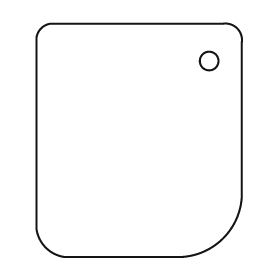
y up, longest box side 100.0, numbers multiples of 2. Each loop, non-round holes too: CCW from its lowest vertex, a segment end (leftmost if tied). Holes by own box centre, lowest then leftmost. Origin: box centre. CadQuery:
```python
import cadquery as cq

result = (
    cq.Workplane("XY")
    .moveTo(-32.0, -50.0)
    .lineTo(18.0, -50.0)
    .threePointArc((36.0, -42.0), (44.0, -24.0))
    .lineTo(44.0, 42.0)
    .threePointArc((42.0, 48.0), (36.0, 50.0))
    .lineTo(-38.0, 50.0)
    .threePointArc((-42.0, 48.0), (-44.0, 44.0))
    .lineTo(-44.0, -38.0)
    .threePointArc((-40.0, -46.0), (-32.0, -50.0))
    .close()
    .moveTo(30.0, 34.0)
    .circle(4.0)
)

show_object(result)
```